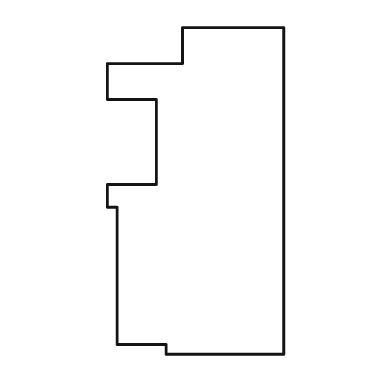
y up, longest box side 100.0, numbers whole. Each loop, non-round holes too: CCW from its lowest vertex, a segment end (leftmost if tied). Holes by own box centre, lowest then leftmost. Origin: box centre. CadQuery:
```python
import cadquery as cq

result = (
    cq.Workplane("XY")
    .moveTo(-9.0, -50.0)
    .lineTo(27.0, -50.0)
    .lineTo(27.0, 50.0)
    .lineTo(-4.0, 50.0)
    .lineTo(-4.0, 39.0)
    .lineTo(-27.0, 39.0)
    .lineTo(-27.0, 28.0)
    .lineTo(-12.0, 28.0)
    .lineTo(-12.0, 2.0)
    .lineTo(-27.0, 2.0)
    .lineTo(-27.0, -5.0)
    .lineTo(-24.0, -5.0)
    .lineTo(-24.0, -47.0)
    .lineTo(-9.0, -47.0)
    .close()
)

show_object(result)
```